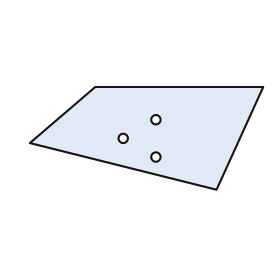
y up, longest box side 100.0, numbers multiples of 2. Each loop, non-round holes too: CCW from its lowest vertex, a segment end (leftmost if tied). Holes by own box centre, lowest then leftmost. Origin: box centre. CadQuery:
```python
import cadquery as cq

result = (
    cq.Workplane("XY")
    .moveTo(30.0, -22.0)
    .lineTo(50.0, 22.0)
    .lineTo(-22.0, 22.0)
    .lineTo(-50.0, -2.0)
    .close()
    .moveTo(4.0, -8.0)
    .circle(2.0)
    .moveTo(-10.0, 0.0)
    .circle(2.0)
    .moveTo(4.0, 8.0)
    .circle(2.0)
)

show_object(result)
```